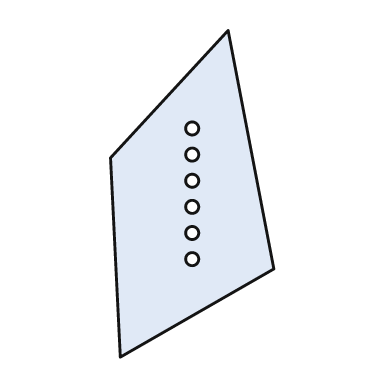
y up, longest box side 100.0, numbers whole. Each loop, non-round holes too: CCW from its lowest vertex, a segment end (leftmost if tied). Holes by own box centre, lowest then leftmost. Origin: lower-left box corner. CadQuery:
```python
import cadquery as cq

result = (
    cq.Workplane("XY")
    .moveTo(3.0, 0.0)
    .lineTo(50.0, 27.0)
    .lineTo(36.0, 100.0)
    .lineTo(0.0, 61.0)
    .close()
    .moveTo(25.0, 30.0)
    .circle(2.0)
    .moveTo(25.0, 38.0)
    .circle(2.0)
    .moveTo(25.0, 46.0)
    .circle(2.0)
    .moveTo(25.0, 54.0)
    .circle(2.0)
    .moveTo(25.0, 62.0)
    .circle(2.0)
    .moveTo(25.0, 70.0)
    .circle(2.0)
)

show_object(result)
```